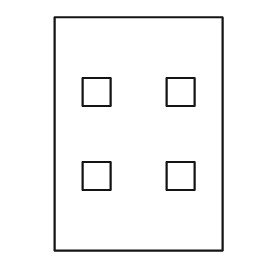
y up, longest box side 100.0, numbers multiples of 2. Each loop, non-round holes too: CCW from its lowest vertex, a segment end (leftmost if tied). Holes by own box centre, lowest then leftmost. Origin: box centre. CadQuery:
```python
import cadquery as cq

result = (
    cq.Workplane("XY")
    .moveTo(-36.0, -50.0)
    .lineTo(36.0, -50.0)
    .lineTo(36.0, 50.0)
    .lineTo(-36.0, 50.0)
    .close()
    .moveTo(-24.0, -24.0)
    .lineTo(-12.0, -24.0)
    .lineTo(-12.0, -12.0)
    .lineTo(-24.0, -12.0)
    .close()
    .moveTo(12.0, -24.0)
    .lineTo(24.0, -24.0)
    .lineTo(24.0, -12.0)
    .lineTo(12.0, -12.0)
    .close()
    .moveTo(-24.0, 12.0)
    .lineTo(-12.0, 12.0)
    .lineTo(-12.0, 24.0)
    .lineTo(-24.0, 24.0)
    .close()
    .moveTo(12.0, 12.0)
    .lineTo(24.0, 12.0)
    .lineTo(24.0, 24.0)
    .lineTo(12.0, 24.0)
    .close()
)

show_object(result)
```